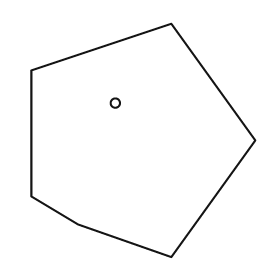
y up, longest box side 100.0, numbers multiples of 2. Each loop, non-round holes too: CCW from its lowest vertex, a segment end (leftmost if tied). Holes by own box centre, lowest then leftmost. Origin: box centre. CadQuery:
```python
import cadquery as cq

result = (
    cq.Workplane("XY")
    .moveTo(12.0, -50.0)
    .lineTo(48.0, 0.0)
    .lineTo(12.0, 50.0)
    .lineTo(-48.0, 30.0)
    .lineTo(-48.0, -24.0)
    .lineTo(-28.0, -36.0)
    .close()
    .moveTo(-12.0, 16.0)
    .circle(2.0)
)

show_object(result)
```